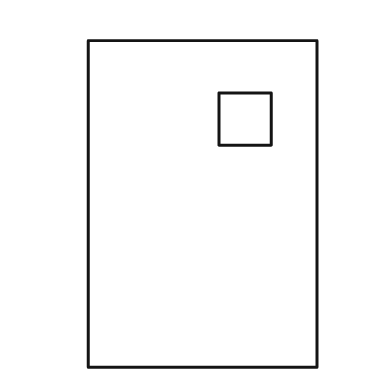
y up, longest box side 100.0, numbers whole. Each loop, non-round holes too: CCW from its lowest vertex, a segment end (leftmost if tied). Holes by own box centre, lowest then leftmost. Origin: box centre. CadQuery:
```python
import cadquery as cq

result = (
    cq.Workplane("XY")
    .moveTo(-35.0, -50.0)
    .lineTo(35.0, -50.0)
    .lineTo(35.0, 50.0)
    .lineTo(-35.0, 50.0)
    .close()
    .moveTo(5.0, 18.0)
    .lineTo(21.0, 18.0)
    .lineTo(21.0, 34.0)
    .lineTo(5.0, 34.0)
    .close()
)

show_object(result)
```